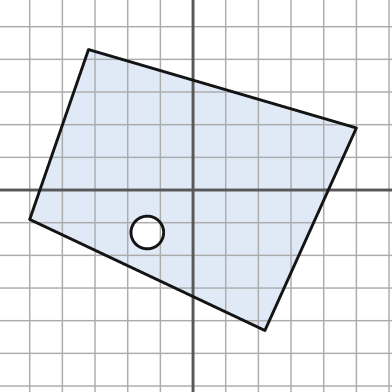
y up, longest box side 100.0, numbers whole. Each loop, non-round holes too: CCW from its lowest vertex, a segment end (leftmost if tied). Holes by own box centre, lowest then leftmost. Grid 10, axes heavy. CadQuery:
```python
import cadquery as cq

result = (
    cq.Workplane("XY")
    .moveTo(22.0, -43.0)
    .lineTo(50.0, 19.0)
    .lineTo(-32.0, 43.0)
    .lineTo(-50.0, -9.0)
    .close()
    .moveTo(-14.0, -13.0)
    .circle(5.0)
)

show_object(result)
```